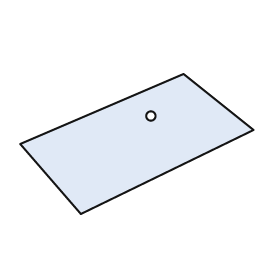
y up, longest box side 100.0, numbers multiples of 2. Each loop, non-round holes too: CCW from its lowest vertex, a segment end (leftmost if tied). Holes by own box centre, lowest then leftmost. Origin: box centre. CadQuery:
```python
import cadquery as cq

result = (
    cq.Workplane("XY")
    .moveTo(-24.0, -30.0)
    .lineTo(50.0, 6.0)
    .lineTo(20.0, 30.0)
    .lineTo(-50.0, 0.0)
    .close()
    .moveTo(6.0, 12.0)
    .circle(2.0)
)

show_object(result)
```